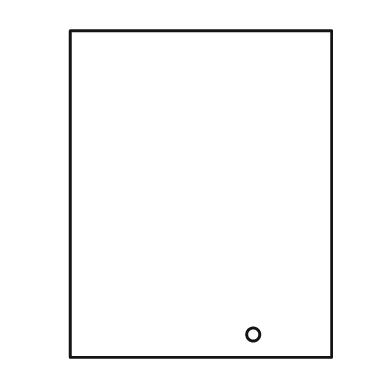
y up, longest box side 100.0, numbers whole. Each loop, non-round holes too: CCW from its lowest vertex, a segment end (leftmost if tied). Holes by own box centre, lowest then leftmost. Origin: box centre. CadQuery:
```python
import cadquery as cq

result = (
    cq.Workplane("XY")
    .moveTo(-40.0, -50.0)
    .lineTo(40.0, -50.0)
    .lineTo(40.0, 50.0)
    .lineTo(-40.0, 50.0)
    .close()
    .moveTo(16.0, -43.0)
    .circle(2.0)
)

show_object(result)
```